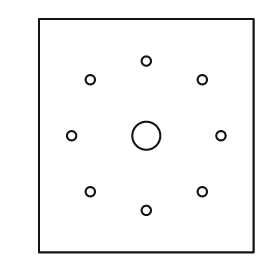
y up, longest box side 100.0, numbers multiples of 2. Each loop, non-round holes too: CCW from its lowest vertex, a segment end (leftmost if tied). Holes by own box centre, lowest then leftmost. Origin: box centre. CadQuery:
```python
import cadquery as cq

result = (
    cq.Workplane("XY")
    .moveTo(-46.0, -50.0)
    .lineTo(46.0, -50.0)
    .lineTo(46.0, 50.0)
    .lineTo(-46.0, 50.0)
    .close()
    .moveTo(0.0, -32.0)
    .circle(2.0)
    .moveTo(-24.0, -24.0)
    .circle(2.0)
    .moveTo(24.0, -24.0)
    .circle(2.0)
    .moveTo(-32.0, 0.0)
    .circle(2.0)
    .moveTo(0.0, 0.0)
    .circle(6.0)
    .moveTo(32.0, 0.0)
    .circle(2.0)
    .moveTo(-24.0, 24.0)
    .circle(2.0)
    .moveTo(24.0, 24.0)
    .circle(2.0)
    .moveTo(0.0, 32.0)
    .circle(2.0)
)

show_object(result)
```